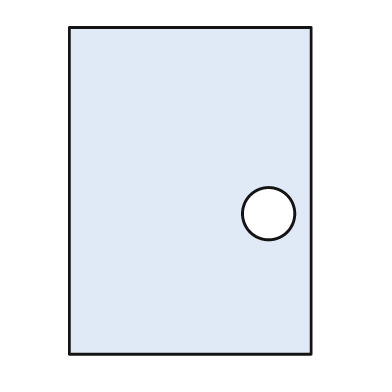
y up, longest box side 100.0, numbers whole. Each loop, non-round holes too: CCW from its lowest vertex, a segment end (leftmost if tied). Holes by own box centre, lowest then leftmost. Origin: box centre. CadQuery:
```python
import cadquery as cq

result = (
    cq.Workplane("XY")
    .moveTo(-37.0, -50.0)
    .lineTo(37.0, -50.0)
    .lineTo(37.0, 50.0)
    .lineTo(-37.0, 50.0)
    .close()
    .moveTo(24.0, -7.0)
    .circle(8.0)
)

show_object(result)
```